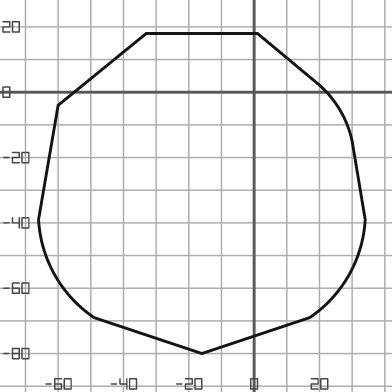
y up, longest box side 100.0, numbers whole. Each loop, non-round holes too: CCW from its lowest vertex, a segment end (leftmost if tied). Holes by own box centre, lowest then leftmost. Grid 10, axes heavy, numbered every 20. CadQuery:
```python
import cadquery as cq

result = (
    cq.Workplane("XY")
    .moveTo(-16.0, -80.0)
    .lineTo(17.0, -69.0)
    .threePointArc((29.0, -56.0), (34.0, -39.0))
    .lineTo(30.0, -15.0)
    .threePointArc((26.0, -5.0), (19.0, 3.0))
    .lineTo(1.0, 18.0)
    .lineTo(-33.0, 18.0)
    .lineTo(-60.0, -4.0)
    .lineTo(-66.0, -39.0)
    .threePointArc((-61.0, -56.0), (-49.0, -69.0))
    .close()
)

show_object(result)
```